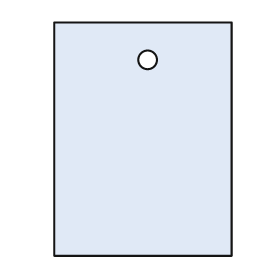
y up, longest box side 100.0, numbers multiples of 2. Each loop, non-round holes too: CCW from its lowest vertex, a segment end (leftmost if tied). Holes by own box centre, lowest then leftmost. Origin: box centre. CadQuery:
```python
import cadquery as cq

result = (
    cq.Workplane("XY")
    .moveTo(-38.0, -50.0)
    .lineTo(38.0, -50.0)
    .lineTo(38.0, 50.0)
    .lineTo(-38.0, 50.0)
    .close()
    .moveTo(2.0, 34.0)
    .circle(4.0)
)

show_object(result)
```